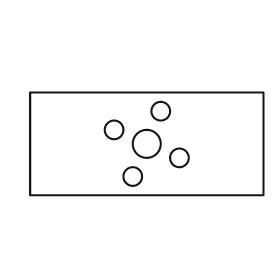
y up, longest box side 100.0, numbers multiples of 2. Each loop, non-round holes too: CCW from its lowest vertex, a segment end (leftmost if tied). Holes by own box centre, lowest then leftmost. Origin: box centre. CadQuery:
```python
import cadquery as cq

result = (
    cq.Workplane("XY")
    .moveTo(-50.0, -22.0)
    .lineTo(50.0, -22.0)
    .lineTo(50.0, 22.0)
    .lineTo(-50.0, 22.0)
    .close()
    .moveTo(-6.0, -14.0)
    .circle(4.0)
    .moveTo(14.0, -6.0)
    .circle(4.0)
    .moveTo(0.0, 0.0)
    .circle(6.0)
    .moveTo(-14.0, 6.0)
    .circle(4.0)
    .moveTo(6.0, 14.0)
    .circle(4.0)
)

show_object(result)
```